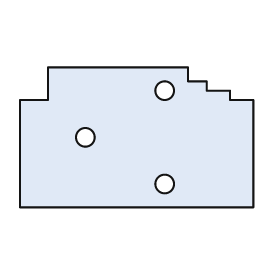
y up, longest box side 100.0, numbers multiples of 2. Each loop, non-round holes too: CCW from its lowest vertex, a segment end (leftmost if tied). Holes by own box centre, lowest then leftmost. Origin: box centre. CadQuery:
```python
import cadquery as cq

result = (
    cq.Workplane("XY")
    .moveTo(-50.0, -30.0)
    .lineTo(50.0, -30.0)
    .lineTo(50.0, 16.0)
    .lineTo(40.0, 16.0)
    .lineTo(40.0, 20.0)
    .lineTo(30.0, 20.0)
    .lineTo(30.0, 24.0)
    .lineTo(22.0, 24.0)
    .lineTo(22.0, 30.0)
    .lineTo(-38.0, 30.0)
    .lineTo(-38.0, 16.0)
    .lineTo(-50.0, 16.0)
    .close()
    .moveTo(12.0, -20.0)
    .circle(4.0)
    .moveTo(-22.0, 0.0)
    .circle(4.0)
    .moveTo(12.0, 20.0)
    .circle(4.0)
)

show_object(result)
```